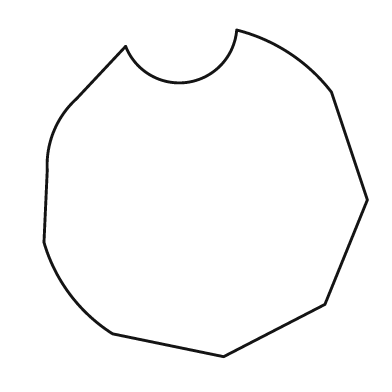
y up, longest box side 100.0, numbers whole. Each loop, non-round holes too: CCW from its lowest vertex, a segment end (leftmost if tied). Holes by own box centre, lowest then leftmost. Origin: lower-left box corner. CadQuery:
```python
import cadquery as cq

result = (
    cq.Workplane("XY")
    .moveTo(55.0, 0.0)
    .lineTo(86.0, 16.0)
    .lineTo(99.0, 48.0)
    .lineTo(88.0, 81.0)
    .threePointArc((75.0, 93.0), (59.0, 100.0))
    .threePointArc((44.0, 84.0), (25.0, 95.0))
    .lineTo(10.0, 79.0)
    .threePointArc((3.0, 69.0), (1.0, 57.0))
    .lineTo(0.0, 35.0)
    .threePointArc((8.0, 19.0), (21.0, 7.0))
    .close()
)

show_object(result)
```